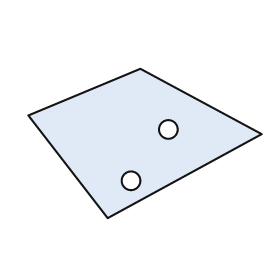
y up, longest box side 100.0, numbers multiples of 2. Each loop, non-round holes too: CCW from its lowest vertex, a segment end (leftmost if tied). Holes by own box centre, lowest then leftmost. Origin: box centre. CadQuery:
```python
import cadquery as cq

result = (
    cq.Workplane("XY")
    .moveTo(-16.0, -32.0)
    .lineTo(50.0, 4.0)
    .lineTo(-2.0, 32.0)
    .lineTo(-50.0, 12.0)
    .close()
    .moveTo(-6.0, -16.0)
    .circle(4.0)
    .moveTo(10.0, 6.0)
    .circle(4.0)
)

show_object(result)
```